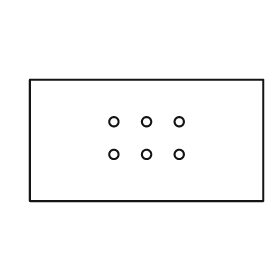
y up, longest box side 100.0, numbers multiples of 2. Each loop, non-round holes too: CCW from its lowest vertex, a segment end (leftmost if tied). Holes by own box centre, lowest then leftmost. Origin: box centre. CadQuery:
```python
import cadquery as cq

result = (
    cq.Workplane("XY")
    .moveTo(-50.0, -26.0)
    .lineTo(50.0, -26.0)
    .lineTo(50.0, 26.0)
    .lineTo(-50.0, 26.0)
    .close()
    .moveTo(-14.0, -6.0)
    .circle(2.0)
    .moveTo(0.0, -6.0)
    .circle(2.0)
    .moveTo(14.0, -6.0)
    .circle(2.0)
    .moveTo(-14.0, 8.0)
    .circle(2.0)
    .moveTo(0.0, 8.0)
    .circle(2.0)
    .moveTo(14.0, 8.0)
    .circle(2.0)
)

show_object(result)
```